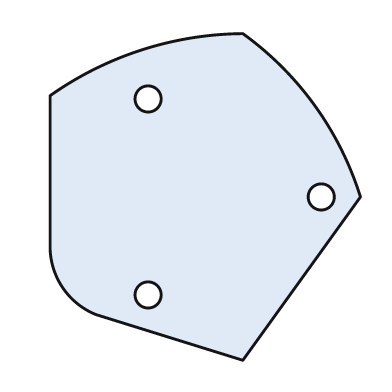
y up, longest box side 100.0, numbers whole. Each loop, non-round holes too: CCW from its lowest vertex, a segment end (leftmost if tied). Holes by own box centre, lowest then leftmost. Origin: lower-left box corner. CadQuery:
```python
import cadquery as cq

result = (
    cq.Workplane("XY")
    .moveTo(59.0, 0.0)
    .lineTo(95.0, 50.0)
    .threePointArc((81.0, 78.0), (59.0, 100.0))
    .threePointArc((28.0, 95.0), (0.0, 81.0))
    .lineTo(0.0, 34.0)
    .threePointArc((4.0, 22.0), (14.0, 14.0))
    .close()
    .moveTo(30.0, 20.0)
    .circle(4.0)
    .moveTo(83.0, 50.0)
    .circle(4.0)
    .moveTo(30.0, 80.0)
    .circle(4.0)
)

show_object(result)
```